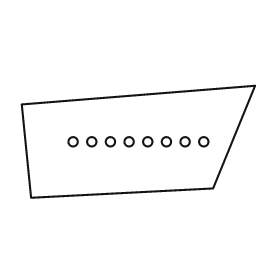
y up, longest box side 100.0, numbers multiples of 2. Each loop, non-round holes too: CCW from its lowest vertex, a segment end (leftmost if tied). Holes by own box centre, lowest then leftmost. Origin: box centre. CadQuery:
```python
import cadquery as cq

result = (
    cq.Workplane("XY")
    .moveTo(-46.0, -24.0)
    .lineTo(32.0, -20.0)
    .lineTo(50.0, 24.0)
    .lineTo(-50.0, 16.0)
    .close()
    .moveTo(-28.0, 0.0)
    .circle(2.0)
    .moveTo(-20.0, 0.0)
    .circle(2.0)
    .moveTo(-12.0, 0.0)
    .circle(2.0)
    .moveTo(-4.0, 0.0)
    .circle(2.0)
    .moveTo(4.0, 0.0)
    .circle(2.0)
    .moveTo(12.0, 0.0)
    .circle(2.0)
    .moveTo(20.0, 0.0)
    .circle(2.0)
    .moveTo(28.0, 0.0)
    .circle(2.0)
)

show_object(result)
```